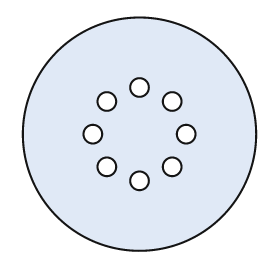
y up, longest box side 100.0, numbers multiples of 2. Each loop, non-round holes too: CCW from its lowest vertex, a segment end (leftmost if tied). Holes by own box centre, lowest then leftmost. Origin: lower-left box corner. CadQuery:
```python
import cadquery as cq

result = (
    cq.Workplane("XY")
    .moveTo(50.0, 50.0)
    .circle(50.0)
    .moveTo(50.0, 30.0)
    .circle(4.0)
    .moveTo(36.0, 36.0)
    .circle(4.0)
    .moveTo(64.0, 36.0)
    .circle(4.0)
    .moveTo(30.0, 50.0)
    .circle(4.0)
    .moveTo(70.0, 50.0)
    .circle(4.0)
    .moveTo(36.0, 64.0)
    .circle(4.0)
    .moveTo(64.0, 64.0)
    .circle(4.0)
    .moveTo(50.0, 70.0)
    .circle(4.0)
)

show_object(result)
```